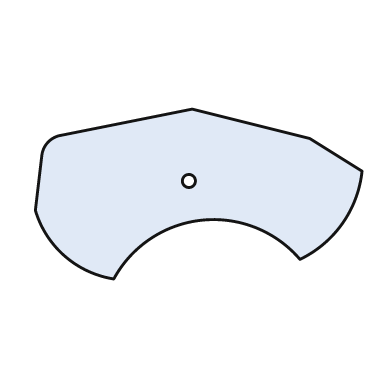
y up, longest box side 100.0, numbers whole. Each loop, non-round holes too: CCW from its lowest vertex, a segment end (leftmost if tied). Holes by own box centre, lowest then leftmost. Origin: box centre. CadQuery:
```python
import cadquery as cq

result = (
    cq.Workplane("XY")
    .moveTo(-26.0, -26.0)
    .threePointArc((1.0, -8.0), (31.0, -20.0))
    .threePointArc((44.0, -9.0), (50.0, 7.0))
    .lineTo(34.0, 17.0)
    .lineTo(-2.0, 26.0)
    .lineTo(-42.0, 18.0)
    .threePointArc((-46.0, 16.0), (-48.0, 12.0))
    .lineTo(-50.0, -5.0)
    .threePointArc((-41.0, -19.0), (-26.0, -26.0))
    .close()
    .moveTo(-3.0, 4.0)
    .circle(2.0)
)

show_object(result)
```